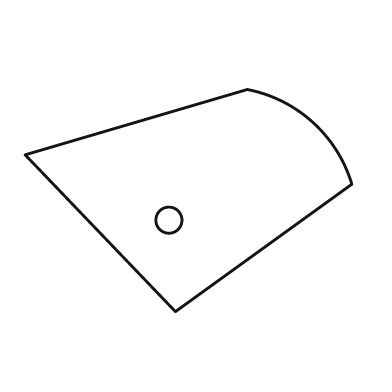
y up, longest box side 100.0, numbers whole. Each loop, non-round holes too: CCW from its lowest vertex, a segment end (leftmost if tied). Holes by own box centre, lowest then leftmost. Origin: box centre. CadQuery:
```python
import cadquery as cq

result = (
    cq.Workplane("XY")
    .moveTo(-4.0, -34.0)
    .lineTo(50.0, 5.0)
    .threePointArc((38.0, 24.0), (18.0, 34.0))
    .lineTo(-50.0, 14.0)
    .close()
    .moveTo(-6.0, -6.0)
    .circle(4.0)
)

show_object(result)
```